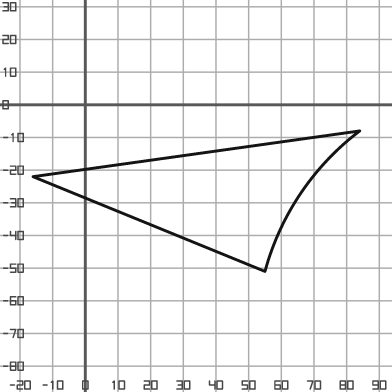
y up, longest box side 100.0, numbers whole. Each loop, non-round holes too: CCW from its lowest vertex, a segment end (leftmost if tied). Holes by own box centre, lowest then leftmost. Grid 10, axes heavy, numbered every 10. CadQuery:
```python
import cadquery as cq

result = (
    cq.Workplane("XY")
    .moveTo(55.0, -51.0)
    .threePointArc((66.0, -27.0), (84.0, -8.0))
    .lineTo(-16.0, -22.0)
    .close()
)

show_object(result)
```